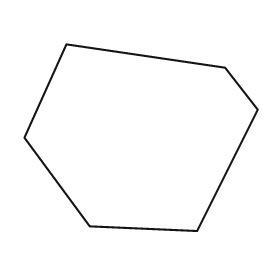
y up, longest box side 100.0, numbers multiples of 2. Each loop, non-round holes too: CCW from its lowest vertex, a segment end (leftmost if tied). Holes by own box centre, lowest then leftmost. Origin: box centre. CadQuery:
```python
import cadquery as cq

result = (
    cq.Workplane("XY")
    .moveTo(24.0, -40.0)
    .lineTo(50.0, 12.0)
    .lineTo(36.0, 30.0)
    .lineTo(-32.0, 40.0)
    .lineTo(-50.0, 0.0)
    .lineTo(-22.0, -38.0)
    .close()
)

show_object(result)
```